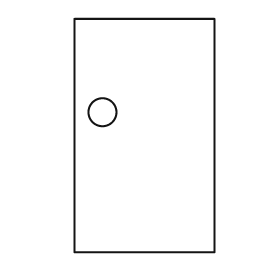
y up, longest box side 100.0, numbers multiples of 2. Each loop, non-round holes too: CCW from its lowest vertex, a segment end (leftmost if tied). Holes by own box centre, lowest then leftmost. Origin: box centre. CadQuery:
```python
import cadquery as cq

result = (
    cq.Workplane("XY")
    .moveTo(-30.0, -50.0)
    .lineTo(30.0, -50.0)
    .lineTo(30.0, 50.0)
    .lineTo(-30.0, 50.0)
    .close()
    .moveTo(-18.0, 10.0)
    .circle(6.0)
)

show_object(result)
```